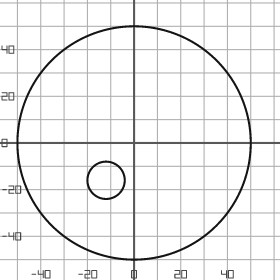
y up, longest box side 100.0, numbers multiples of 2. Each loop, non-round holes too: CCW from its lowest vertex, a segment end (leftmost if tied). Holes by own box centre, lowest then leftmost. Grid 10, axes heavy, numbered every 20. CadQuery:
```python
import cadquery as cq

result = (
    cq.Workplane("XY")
    .moveTo(0.0, 0.0)
    .circle(50.0)
    .moveTo(-12.0, -16.0)
    .circle(8.0)
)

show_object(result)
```